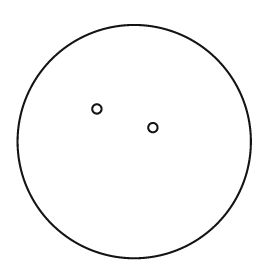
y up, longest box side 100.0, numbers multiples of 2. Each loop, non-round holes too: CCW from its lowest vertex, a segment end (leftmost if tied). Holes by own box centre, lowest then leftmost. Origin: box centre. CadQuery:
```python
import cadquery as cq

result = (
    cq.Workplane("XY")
    .moveTo(0.0, 0.0)
    .circle(50.0)
    .moveTo(8.0, 6.0)
    .circle(2.0)
    .moveTo(-16.0, 14.0)
    .circle(2.0)
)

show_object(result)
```